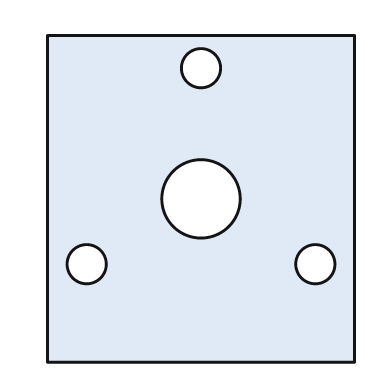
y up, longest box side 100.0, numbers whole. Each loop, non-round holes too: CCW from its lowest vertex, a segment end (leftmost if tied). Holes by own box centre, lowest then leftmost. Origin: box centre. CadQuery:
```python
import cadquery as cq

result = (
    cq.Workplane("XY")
    .moveTo(-47.0, -50.0)
    .lineTo(47.0, -50.0)
    .lineTo(47.0, 50.0)
    .lineTo(-47.0, 50.0)
    .close()
    .moveTo(-35.0, -20.0)
    .circle(6.0)
    .moveTo(35.0, -20.0)
    .circle(6.0)
    .moveTo(0.0, 0.0)
    .circle(12.0)
    .moveTo(0.0, 40.0)
    .circle(6.0)
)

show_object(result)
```